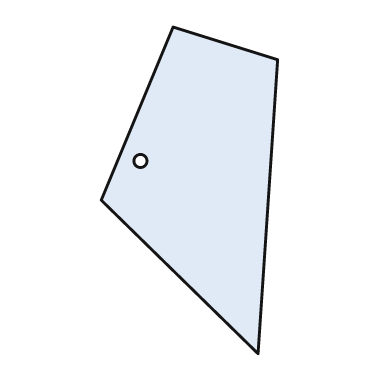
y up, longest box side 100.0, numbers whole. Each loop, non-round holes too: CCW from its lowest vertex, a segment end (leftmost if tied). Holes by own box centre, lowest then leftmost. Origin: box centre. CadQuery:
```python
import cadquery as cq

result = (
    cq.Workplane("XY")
    .moveTo(21.0, -50.0)
    .lineTo(27.0, 40.0)
    .lineTo(-5.0, 50.0)
    .lineTo(-27.0, -3.0)
    .close()
    .moveTo(-15.0, 9.0)
    .circle(2.0)
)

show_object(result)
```